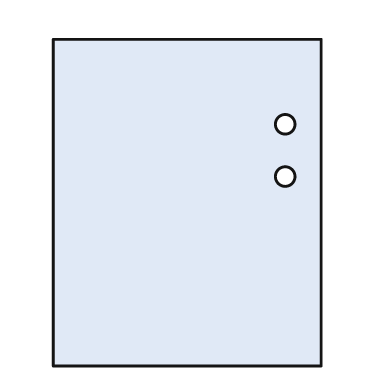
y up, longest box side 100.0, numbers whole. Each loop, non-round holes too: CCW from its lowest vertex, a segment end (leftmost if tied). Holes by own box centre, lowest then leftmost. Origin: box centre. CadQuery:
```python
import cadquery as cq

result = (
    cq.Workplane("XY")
    .moveTo(-41.0, -50.0)
    .lineTo(41.0, -50.0)
    .lineTo(41.0, 50.0)
    .lineTo(-41.0, 50.0)
    .close()
    .moveTo(30.0, 8.0)
    .circle(3.0)
    .moveTo(30.0, 24.0)
    .circle(3.0)
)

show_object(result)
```